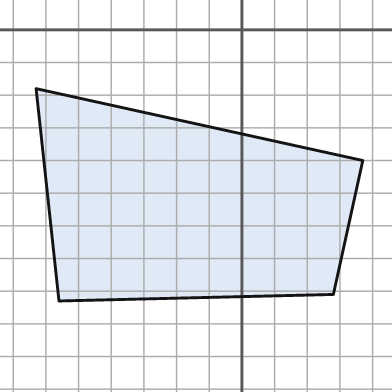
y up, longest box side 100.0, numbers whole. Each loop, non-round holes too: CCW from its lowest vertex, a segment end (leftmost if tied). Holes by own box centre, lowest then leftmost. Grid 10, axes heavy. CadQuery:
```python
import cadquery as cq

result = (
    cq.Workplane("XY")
    .moveTo(-56.0, -83.0)
    .lineTo(28.0, -81.0)
    .lineTo(37.0, -40.0)
    .lineTo(-63.0, -18.0)
    .close()
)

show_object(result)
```